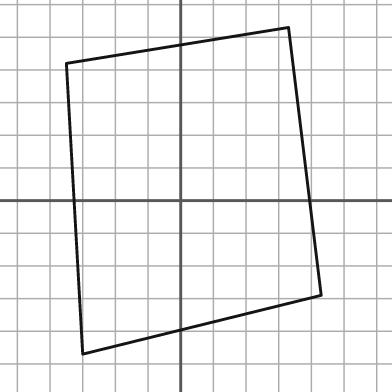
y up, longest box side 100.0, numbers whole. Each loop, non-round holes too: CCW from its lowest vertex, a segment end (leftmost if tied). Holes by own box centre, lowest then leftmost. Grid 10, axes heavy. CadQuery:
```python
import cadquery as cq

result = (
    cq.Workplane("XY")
    .moveTo(-30.0, -47.0)
    .lineTo(43.0, -29.0)
    .lineTo(33.0, 53.0)
    .lineTo(-35.0, 42.0)
    .close()
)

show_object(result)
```